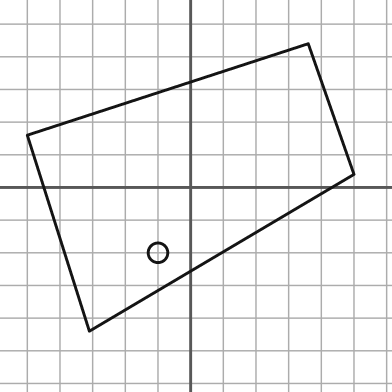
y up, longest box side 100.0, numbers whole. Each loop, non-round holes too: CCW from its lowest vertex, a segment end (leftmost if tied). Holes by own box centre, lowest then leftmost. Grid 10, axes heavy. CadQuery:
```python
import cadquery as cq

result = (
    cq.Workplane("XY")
    .moveTo(-31.0, -44.0)
    .lineTo(50.0, 4.0)
    .lineTo(36.0, 44.0)
    .lineTo(-50.0, 16.0)
    .close()
    .moveTo(-10.0, -20.0)
    .circle(3.0)
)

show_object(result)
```